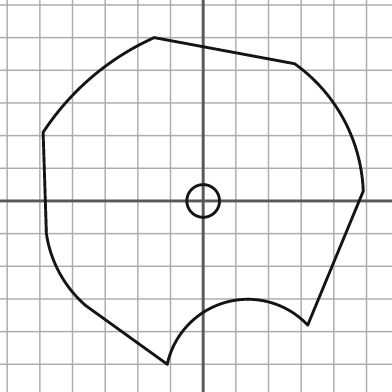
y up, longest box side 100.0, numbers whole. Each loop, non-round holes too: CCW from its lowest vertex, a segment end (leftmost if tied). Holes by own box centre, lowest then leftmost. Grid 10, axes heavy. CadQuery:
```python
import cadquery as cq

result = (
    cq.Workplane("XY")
    .moveTo(-11.0, -50.0)
    .threePointArc((7.0, -31.0), (32.0, -38.0))
    .lineTo(49.0, 3.0)
    .threePointArc((43.0, 25.0), (28.0, 42.0))
    .lineTo(-15.0, 50.0)
    .threePointArc((-34.0, 38.0), (-49.0, 21.0))
    .lineTo(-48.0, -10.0)
    .threePointArc((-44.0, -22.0), (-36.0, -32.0))
    .close()
    .moveTo(0.0, 0.0)
    .circle(5.0)
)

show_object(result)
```